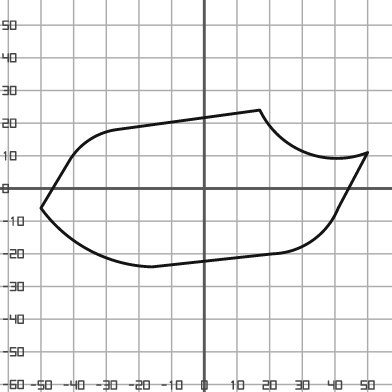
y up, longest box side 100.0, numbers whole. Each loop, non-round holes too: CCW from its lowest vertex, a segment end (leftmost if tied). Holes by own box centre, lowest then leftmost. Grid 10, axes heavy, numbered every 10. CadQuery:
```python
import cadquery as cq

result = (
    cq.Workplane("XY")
    .moveTo(-16.0, -24.0)
    .lineTo(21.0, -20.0)
    .threePointArc((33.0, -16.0), (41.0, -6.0))
    .lineTo(50.0, 11.0)
    .threePointArc((31.0, 11.0), (17.0, 24.0))
    .lineTo(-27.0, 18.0)
    .threePointArc((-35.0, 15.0), (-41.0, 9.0))
    .lineTo(-50.0, -6.0)
    .threePointArc((-35.0, -19.0), (-16.0, -24.0))
    .close()
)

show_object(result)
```